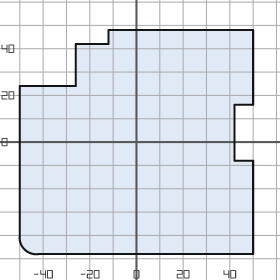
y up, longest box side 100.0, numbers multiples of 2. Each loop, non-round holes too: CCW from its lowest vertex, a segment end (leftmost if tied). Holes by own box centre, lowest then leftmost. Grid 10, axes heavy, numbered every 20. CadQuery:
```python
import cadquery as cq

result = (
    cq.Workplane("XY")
    .moveTo(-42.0, -48.0)
    .lineTo(50.0, -48.0)
    .lineTo(50.0, -8.0)
    .lineTo(42.0, -8.0)
    .lineTo(42.0, 16.0)
    .lineTo(50.0, 16.0)
    .lineTo(50.0, 48.0)
    .lineTo(-12.0, 48.0)
    .lineTo(-12.0, 42.0)
    .lineTo(-26.0, 42.0)
    .lineTo(-26.0, 24.0)
    .lineTo(-50.0, 24.0)
    .lineTo(-50.0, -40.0)
    .threePointArc((-48.0, -46.0), (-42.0, -48.0))
    .close()
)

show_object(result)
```